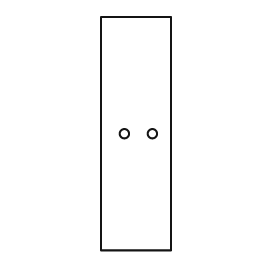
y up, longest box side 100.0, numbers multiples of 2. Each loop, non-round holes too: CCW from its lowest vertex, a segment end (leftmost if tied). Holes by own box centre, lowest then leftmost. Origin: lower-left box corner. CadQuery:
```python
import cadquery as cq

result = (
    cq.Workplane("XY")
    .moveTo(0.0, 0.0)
    .lineTo(30.0, 0.0)
    .lineTo(30.0, 100.0)
    .lineTo(0.0, 100.0)
    .close()
    .moveTo(10.0, 50.0)
    .circle(2.0)
    .moveTo(22.0, 50.0)
    .circle(2.0)
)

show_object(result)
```